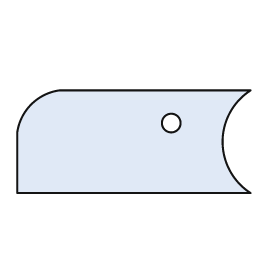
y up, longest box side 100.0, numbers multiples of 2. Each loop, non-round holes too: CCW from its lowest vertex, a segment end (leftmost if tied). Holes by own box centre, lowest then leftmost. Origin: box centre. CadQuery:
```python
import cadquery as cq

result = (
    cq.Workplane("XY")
    .moveTo(-50.0, -22.0)
    .lineTo(50.0, -22.0)
    .threePointArc((38.0, 0.0), (50.0, 22.0))
    .lineTo(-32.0, 22.0)
    .threePointArc((-44.0, 16.0), (-50.0, 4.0))
    .close()
    .moveTo(16.0, 8.0)
    .circle(4.0)
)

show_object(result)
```